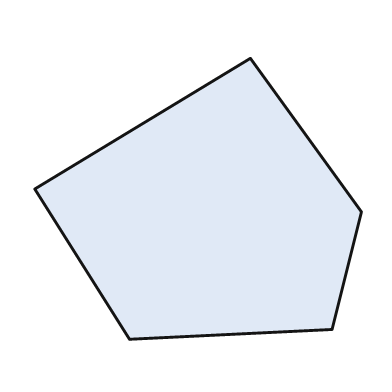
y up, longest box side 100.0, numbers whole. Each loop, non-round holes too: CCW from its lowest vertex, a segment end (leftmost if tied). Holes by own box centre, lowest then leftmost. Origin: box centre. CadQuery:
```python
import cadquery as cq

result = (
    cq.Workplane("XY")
    .moveTo(-21.0, -43.0)
    .lineTo(41.0, -40.0)
    .lineTo(50.0, -4.0)
    .lineTo(16.0, 43.0)
    .lineTo(-50.0, 3.0)
    .close()
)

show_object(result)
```